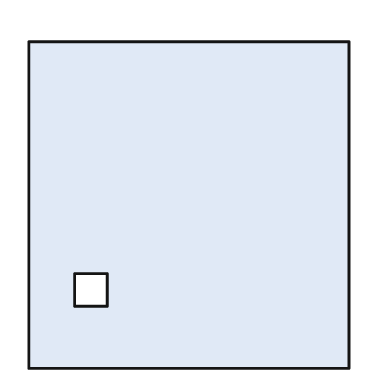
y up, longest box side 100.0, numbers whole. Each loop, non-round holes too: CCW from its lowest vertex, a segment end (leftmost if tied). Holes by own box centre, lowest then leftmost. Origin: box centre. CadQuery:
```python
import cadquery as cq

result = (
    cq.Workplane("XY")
    .moveTo(-49.0, -50.0)
    .lineTo(49.0, -50.0)
    .lineTo(49.0, 50.0)
    .lineTo(-49.0, 50.0)
    .close()
    .moveTo(-35.0, -31.0)
    .lineTo(-25.0, -31.0)
    .lineTo(-25.0, -21.0)
    .lineTo(-35.0, -21.0)
    .close()
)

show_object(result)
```